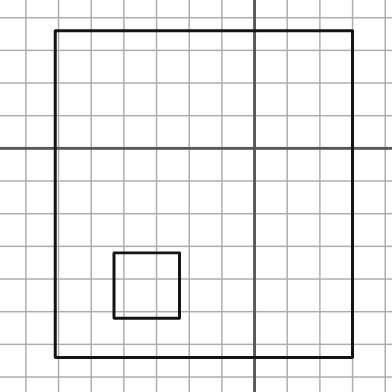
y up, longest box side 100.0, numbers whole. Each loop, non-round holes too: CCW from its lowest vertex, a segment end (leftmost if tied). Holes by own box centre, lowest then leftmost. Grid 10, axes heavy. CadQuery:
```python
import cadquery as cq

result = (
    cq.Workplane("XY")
    .moveTo(-61.0, -64.0)
    .lineTo(30.0, -64.0)
    .lineTo(30.0, 36.0)
    .lineTo(-61.0, 36.0)
    .close()
    .moveTo(-43.0, -52.0)
    .lineTo(-23.0, -52.0)
    .lineTo(-23.0, -32.0)
    .lineTo(-43.0, -32.0)
    .close()
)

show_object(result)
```